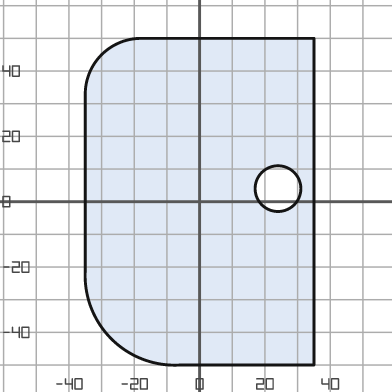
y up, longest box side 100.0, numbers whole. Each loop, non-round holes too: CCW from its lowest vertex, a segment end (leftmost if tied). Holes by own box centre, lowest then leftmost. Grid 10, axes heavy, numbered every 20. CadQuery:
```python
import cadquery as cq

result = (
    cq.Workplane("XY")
    .moveTo(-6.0, -50.0)
    .lineTo(35.0, -50.0)
    .lineTo(35.0, 50.0)
    .lineTo(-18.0, 50.0)
    .threePointArc((-30.0, 45.0), (-35.0, 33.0))
    .lineTo(-35.0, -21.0)
    .threePointArc((-27.0, -42.0), (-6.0, -50.0))
    .close()
    .moveTo(24.0, 4.0)
    .circle(7.0)
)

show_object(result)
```